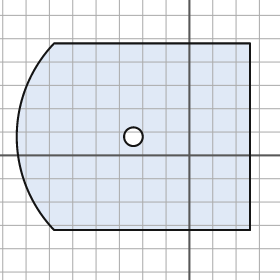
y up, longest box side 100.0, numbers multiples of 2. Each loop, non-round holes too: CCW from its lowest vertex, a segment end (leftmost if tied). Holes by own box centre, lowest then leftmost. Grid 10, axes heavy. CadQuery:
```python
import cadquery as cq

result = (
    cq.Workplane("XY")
    .moveTo(-58.0, -32.0)
    .lineTo(26.0, -32.0)
    .lineTo(26.0, 48.0)
    .lineTo(-58.0, 48.0)
    .threePointArc((-74.0, 8.0), (-58.0, -32.0))
    .close()
    .moveTo(-24.0, 8.0)
    .circle(4.0)
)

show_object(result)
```